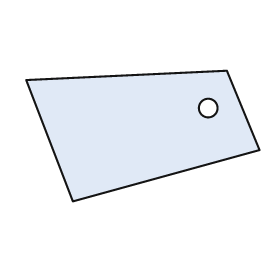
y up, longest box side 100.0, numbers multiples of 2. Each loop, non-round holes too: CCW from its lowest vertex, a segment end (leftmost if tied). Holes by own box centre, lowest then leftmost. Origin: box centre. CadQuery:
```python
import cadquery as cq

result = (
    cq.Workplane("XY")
    .moveTo(-30.0, -28.0)
    .lineTo(50.0, -6.0)
    .lineTo(36.0, 28.0)
    .lineTo(-50.0, 24.0)
    .close()
    .moveTo(28.0, 12.0)
    .circle(4.0)
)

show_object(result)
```